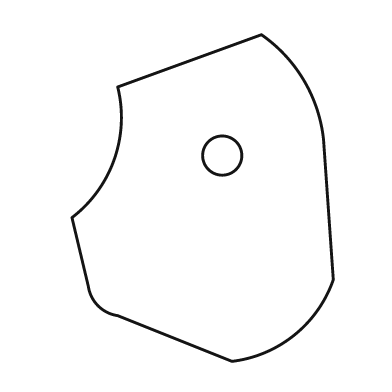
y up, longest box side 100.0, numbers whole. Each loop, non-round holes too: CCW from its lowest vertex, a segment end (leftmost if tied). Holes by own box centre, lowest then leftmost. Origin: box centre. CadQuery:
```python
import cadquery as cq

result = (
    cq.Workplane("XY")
    .moveTo(9.0, -50.0)
    .threePointArc((28.0, -42.0), (40.0, -25.0))
    .lineTo(37.0, 18.0)
    .threePointArc((31.0, 36.0), (18.0, 50.0))
    .lineTo(-26.0, 34.0)
    .threePointArc((-27.0, 12.0), (-40.0, -6.0))
    .lineTo(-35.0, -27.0)
    .threePointArc((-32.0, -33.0), (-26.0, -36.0))
    .close()
    .moveTo(6.0, 13.0)
    .circle(6.0)
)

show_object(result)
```